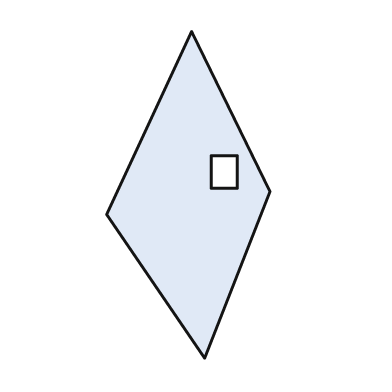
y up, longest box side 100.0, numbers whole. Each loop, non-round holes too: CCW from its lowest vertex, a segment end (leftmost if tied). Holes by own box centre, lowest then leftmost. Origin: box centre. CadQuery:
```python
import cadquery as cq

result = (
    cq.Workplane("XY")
    .moveTo(5.0, -50.0)
    .lineTo(25.0, 1.0)
    .lineTo(1.0, 50.0)
    .lineTo(-25.0, -6.0)
    .close()
    .moveTo(7.0, 2.0)
    .lineTo(15.0, 2.0)
    .lineTo(15.0, 12.0)
    .lineTo(7.0, 12.0)
    .close()
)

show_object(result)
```